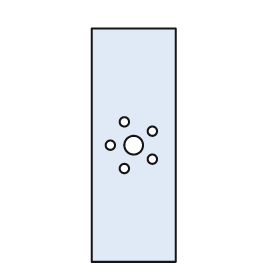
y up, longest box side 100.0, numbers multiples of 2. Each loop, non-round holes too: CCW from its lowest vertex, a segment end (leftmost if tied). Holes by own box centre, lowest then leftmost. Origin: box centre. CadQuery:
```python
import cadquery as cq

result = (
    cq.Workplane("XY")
    .moveTo(-18.0, -50.0)
    .lineTo(18.0, -50.0)
    .lineTo(18.0, 50.0)
    .lineTo(-18.0, 50.0)
    .close()
    .moveTo(-4.0, -10.0)
    .circle(2.0)
    .moveTo(8.0, -6.0)
    .circle(2.0)
    .moveTo(-10.0, 0.0)
    .circle(2.0)
    .moveTo(0.0, 0.0)
    .circle(4.0)
    .moveTo(8.0, 6.0)
    .circle(2.0)
    .moveTo(-4.0, 10.0)
    .circle(2.0)
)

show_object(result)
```